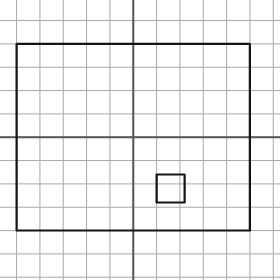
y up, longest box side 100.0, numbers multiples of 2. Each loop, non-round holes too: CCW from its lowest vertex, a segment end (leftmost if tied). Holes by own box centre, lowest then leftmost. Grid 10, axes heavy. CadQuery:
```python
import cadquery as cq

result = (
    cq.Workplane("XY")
    .moveTo(-50.0, -40.0)
    .lineTo(50.0, -40.0)
    .lineTo(50.0, 40.0)
    .lineTo(-50.0, 40.0)
    .close()
    .moveTo(10.0, -28.0)
    .lineTo(22.0, -28.0)
    .lineTo(22.0, -16.0)
    .lineTo(10.0, -16.0)
    .close()
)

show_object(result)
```